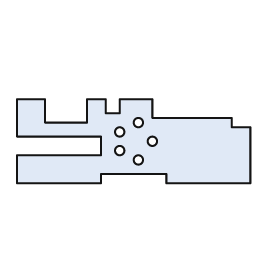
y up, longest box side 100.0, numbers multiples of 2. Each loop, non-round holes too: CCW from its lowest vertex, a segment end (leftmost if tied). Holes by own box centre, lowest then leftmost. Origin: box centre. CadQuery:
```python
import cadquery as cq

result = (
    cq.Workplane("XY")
    .moveTo(-50.0, -18.0)
    .lineTo(-14.0, -18.0)
    .lineTo(-14.0, -14.0)
    .lineTo(14.0, -14.0)
    .lineTo(14.0, -18.0)
    .lineTo(50.0, -18.0)
    .lineTo(50.0, 6.0)
    .lineTo(42.0, 6.0)
    .lineTo(42.0, 10.0)
    .lineTo(8.0, 10.0)
    .lineTo(8.0, 18.0)
    .lineTo(-6.0, 18.0)
    .lineTo(-6.0, 12.0)
    .lineTo(-12.0, 12.0)
    .lineTo(-12.0, 18.0)
    .lineTo(-20.0, 18.0)
    .lineTo(-20.0, 8.0)
    .lineTo(-38.0, 8.0)
    .lineTo(-38.0, 18.0)
    .lineTo(-50.0, 18.0)
    .lineTo(-50.0, 2.0)
    .lineTo(-14.0, 2.0)
    .lineTo(-14.0, -6.0)
    .lineTo(-50.0, -6.0)
    .close()
    .moveTo(2.0, -8.0)
    .circle(2.0)
    .moveTo(-6.0, -4.0)
    .circle(2.0)
    .moveTo(8.0, 0.0)
    .circle(2.0)
    .moveTo(-6.0, 4.0)
    .circle(2.0)
    .moveTo(2.0, 8.0)
    .circle(2.0)
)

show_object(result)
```